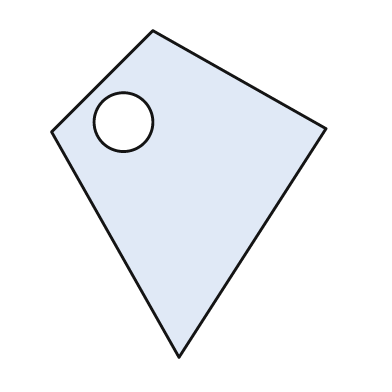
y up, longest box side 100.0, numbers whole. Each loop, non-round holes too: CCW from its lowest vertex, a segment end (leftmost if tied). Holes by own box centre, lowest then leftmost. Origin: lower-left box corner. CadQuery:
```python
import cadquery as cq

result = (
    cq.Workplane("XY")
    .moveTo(39.0, 0.0)
    .lineTo(84.0, 70.0)
    .lineTo(31.0, 100.0)
    .lineTo(0.0, 69.0)
    .close()
    .moveTo(22.0, 72.0)
    .circle(9.0)
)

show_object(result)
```